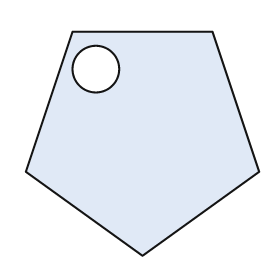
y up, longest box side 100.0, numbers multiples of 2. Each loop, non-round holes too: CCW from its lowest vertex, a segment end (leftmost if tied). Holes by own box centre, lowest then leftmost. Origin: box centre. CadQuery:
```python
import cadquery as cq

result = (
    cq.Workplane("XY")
    .moveTo(0.0, -48.0)
    .lineTo(50.0, -12.0)
    .lineTo(30.0, 48.0)
    .lineTo(-30.0, 48.0)
    .lineTo(-50.0, -12.0)
    .close()
    .moveTo(-20.0, 32.0)
    .circle(10.0)
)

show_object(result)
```